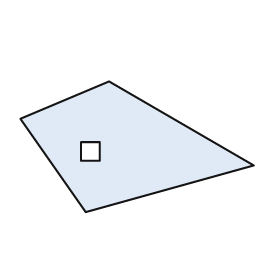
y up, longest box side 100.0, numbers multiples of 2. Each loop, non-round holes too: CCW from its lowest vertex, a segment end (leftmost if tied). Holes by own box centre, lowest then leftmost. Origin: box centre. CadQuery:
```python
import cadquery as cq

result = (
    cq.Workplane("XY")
    .moveTo(-22.0, -28.0)
    .lineTo(50.0, -8.0)
    .lineTo(-12.0, 28.0)
    .lineTo(-50.0, 12.0)
    .close()
    .moveTo(-24.0, -6.0)
    .lineTo(-16.0, -6.0)
    .lineTo(-16.0, 2.0)
    .lineTo(-24.0, 2.0)
    .close()
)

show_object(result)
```